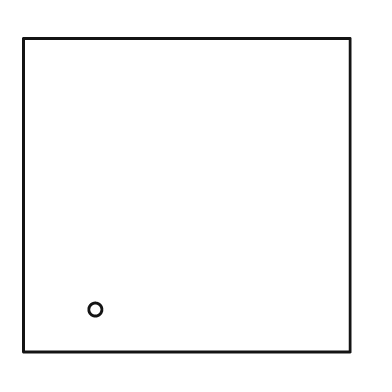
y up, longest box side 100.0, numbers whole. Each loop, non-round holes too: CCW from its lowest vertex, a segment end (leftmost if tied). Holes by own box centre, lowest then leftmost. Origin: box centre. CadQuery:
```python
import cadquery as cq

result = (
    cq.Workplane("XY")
    .moveTo(-50.0, -48.0)
    .lineTo(50.0, -48.0)
    .lineTo(50.0, 48.0)
    .lineTo(-50.0, 48.0)
    .close()
    .moveTo(-28.0, -35.0)
    .circle(2.0)
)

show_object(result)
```